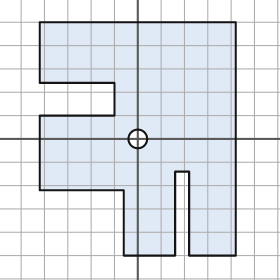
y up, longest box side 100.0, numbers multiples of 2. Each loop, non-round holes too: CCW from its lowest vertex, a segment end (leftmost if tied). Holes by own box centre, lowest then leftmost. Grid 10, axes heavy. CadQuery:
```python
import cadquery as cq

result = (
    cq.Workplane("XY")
    .moveTo(-6.0, -50.0)
    .lineTo(16.0, -50.0)
    .lineTo(16.0, -14.0)
    .lineTo(22.0, -14.0)
    .lineTo(22.0, -50.0)
    .lineTo(42.0, -50.0)
    .lineTo(42.0, 50.0)
    .lineTo(-42.0, 50.0)
    .lineTo(-42.0, 24.0)
    .lineTo(-10.0, 24.0)
    .lineTo(-10.0, 10.0)
    .lineTo(-42.0, 10.0)
    .lineTo(-42.0, -22.0)
    .lineTo(-6.0, -22.0)
    .close()
    .moveTo(0.0, 0.0)
    .circle(4.0)
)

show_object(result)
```